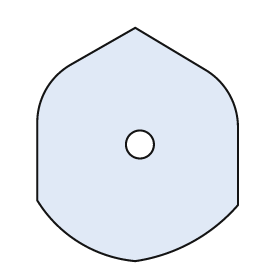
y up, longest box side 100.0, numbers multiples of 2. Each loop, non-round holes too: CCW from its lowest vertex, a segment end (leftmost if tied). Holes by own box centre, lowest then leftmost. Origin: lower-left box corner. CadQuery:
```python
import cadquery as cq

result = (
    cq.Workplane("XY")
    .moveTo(42.0, 0.0)
    .threePointArc((66.0, 8.0), (86.0, 24.0))
    .lineTo(86.0, 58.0)
    .threePointArc((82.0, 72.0), (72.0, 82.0))
    .lineTo(42.0, 100.0)
    .lineTo(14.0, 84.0)
    .threePointArc((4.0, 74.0), (0.0, 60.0))
    .lineTo(0.0, 26.0)
    .threePointArc((18.0, 8.0), (42.0, 0.0))
    .close()
    .moveTo(44.0, 50.0)
    .circle(6.0)
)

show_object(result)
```